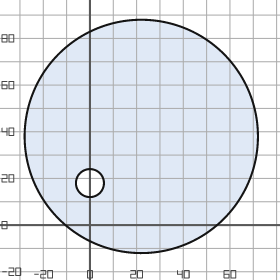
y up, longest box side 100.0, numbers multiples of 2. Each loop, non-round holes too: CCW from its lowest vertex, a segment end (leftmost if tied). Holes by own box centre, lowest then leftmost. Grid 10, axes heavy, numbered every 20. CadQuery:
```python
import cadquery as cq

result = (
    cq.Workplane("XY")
    .moveTo(22.0, 38.0)
    .circle(50.0)
    .moveTo(0.0, 18.0)
    .circle(6.0)
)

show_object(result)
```